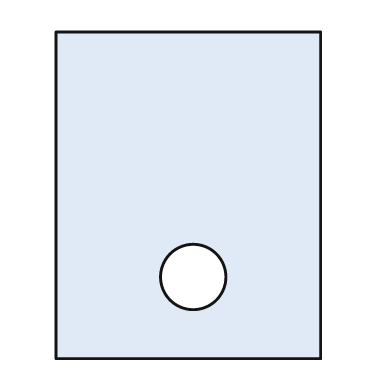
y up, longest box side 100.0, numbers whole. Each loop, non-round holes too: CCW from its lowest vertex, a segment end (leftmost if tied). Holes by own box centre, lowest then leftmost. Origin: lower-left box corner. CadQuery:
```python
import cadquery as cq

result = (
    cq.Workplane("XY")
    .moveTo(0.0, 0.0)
    .lineTo(81.0, 0.0)
    .lineTo(81.0, 100.0)
    .lineTo(0.0, 100.0)
    .close()
    .moveTo(42.0, 25.0)
    .circle(10.0)
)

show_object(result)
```